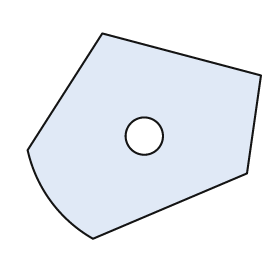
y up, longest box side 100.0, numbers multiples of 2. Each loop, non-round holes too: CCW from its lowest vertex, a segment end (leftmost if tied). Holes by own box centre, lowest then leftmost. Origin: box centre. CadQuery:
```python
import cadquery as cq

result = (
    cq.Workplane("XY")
    .moveTo(-22.0, -44.0)
    .lineTo(44.0, -16.0)
    .lineTo(50.0, 26.0)
    .lineTo(-18.0, 44.0)
    .lineTo(-50.0, -6.0)
    .threePointArc((-40.0, -28.0), (-22.0, -44.0))
    .close()
    .moveTo(0.0, 0.0)
    .circle(8.0)
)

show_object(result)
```